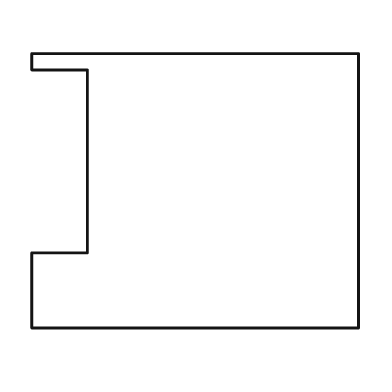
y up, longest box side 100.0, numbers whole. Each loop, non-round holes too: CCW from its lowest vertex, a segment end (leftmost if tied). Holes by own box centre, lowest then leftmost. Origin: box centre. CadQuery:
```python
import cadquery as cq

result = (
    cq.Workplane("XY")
    .moveTo(-50.0, -42.0)
    .lineTo(50.0, -42.0)
    .lineTo(50.0, 42.0)
    .lineTo(-50.0, 42.0)
    .lineTo(-50.0, 37.0)
    .lineTo(-33.0, 37.0)
    .lineTo(-33.0, -19.0)
    .lineTo(-50.0, -19.0)
    .close()
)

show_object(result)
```